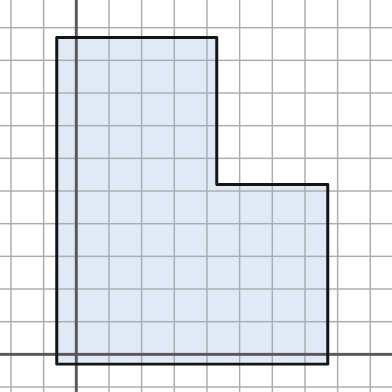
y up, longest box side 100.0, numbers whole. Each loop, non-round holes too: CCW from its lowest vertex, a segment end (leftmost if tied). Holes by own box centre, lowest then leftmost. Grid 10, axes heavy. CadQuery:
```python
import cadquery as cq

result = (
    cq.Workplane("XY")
    .moveTo(-6.0, -3.0)
    .lineTo(77.0, -3.0)
    .lineTo(77.0, 52.0)
    .lineTo(43.0, 52.0)
    .lineTo(43.0, 97.0)
    .lineTo(-6.0, 97.0)
    .close()
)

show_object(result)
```